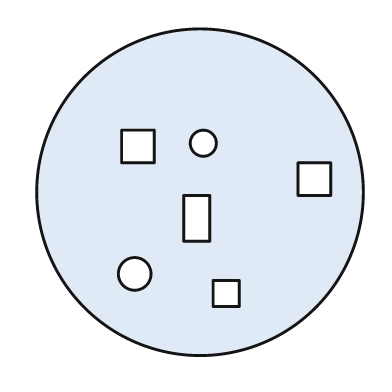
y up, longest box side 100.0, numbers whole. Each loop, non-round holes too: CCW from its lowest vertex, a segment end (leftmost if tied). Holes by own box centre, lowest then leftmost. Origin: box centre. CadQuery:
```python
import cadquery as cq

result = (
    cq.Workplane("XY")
    .moveTo(0.0, 0.0)
    .circle(50.0)
    .moveTo(4.0, -35.0)
    .lineTo(12.0, -35.0)
    .lineTo(12.0, -27.0)
    .lineTo(4.0, -27.0)
    .close()
    .moveTo(-20.0, -25.0)
    .circle(5.0)
    .moveTo(-5.0, -15.0)
    .lineTo(3.0, -15.0)
    .lineTo(3.0, -1.0)
    .lineTo(-5.0, -1.0)
    .close()
    .moveTo(30.0, -1.0)
    .lineTo(40.0, -1.0)
    .lineTo(40.0, 9.0)
    .lineTo(30.0, 9.0)
    .close()
    .moveTo(-24.0, 9.0)
    .lineTo(-14.0, 9.0)
    .lineTo(-14.0, 19.0)
    .lineTo(-24.0, 19.0)
    .close()
    .moveTo(1.0, 15.0)
    .circle(4.0)
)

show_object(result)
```